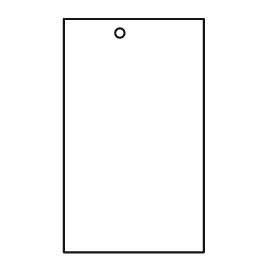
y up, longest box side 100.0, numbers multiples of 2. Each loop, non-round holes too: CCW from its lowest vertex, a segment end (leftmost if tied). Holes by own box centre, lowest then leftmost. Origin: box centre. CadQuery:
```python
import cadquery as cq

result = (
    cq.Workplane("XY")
    .moveTo(-30.0, -50.0)
    .lineTo(30.0, -50.0)
    .lineTo(30.0, 50.0)
    .lineTo(-30.0, 50.0)
    .close()
    .moveTo(-6.0, 44.0)
    .circle(2.0)
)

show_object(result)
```